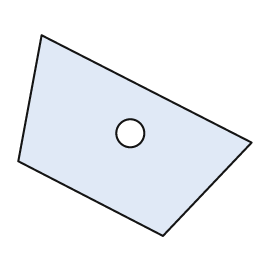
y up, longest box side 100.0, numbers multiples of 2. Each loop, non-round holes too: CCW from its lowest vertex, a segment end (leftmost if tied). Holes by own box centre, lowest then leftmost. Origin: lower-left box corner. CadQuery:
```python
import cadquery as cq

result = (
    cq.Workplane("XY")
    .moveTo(62.0, 0.0)
    .lineTo(100.0, 40.0)
    .lineTo(10.0, 86.0)
    .lineTo(0.0, 32.0)
    .close()
    .moveTo(48.0, 44.0)
    .circle(6.0)
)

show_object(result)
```